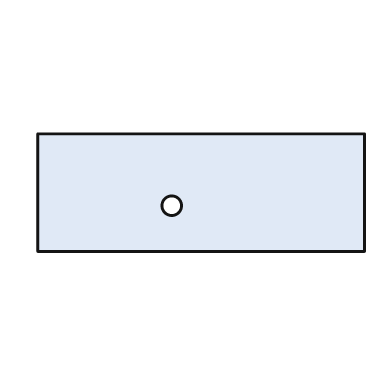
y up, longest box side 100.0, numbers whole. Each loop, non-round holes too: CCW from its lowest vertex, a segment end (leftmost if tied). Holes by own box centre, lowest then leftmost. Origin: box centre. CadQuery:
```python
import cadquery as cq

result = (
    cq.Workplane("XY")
    .moveTo(-50.0, -18.0)
    .lineTo(50.0, -18.0)
    .lineTo(50.0, 18.0)
    .lineTo(-50.0, 18.0)
    .close()
    .moveTo(-9.0, -4.0)
    .circle(3.0)
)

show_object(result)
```